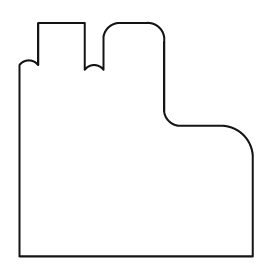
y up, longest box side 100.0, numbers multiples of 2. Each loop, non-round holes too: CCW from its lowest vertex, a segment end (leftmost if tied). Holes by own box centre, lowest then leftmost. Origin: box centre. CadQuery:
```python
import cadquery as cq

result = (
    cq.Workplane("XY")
    .moveTo(-50.0, -50.0)
    .lineTo(50.0, -50.0)
    .lineTo(50.0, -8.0)
    .threePointArc((46.0, 2.0), (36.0, 6.0))
    .lineTo(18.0, 6.0)
    .threePointArc((14.0, 8.0), (12.0, 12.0))
    .lineTo(12.0, 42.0)
    .threePointArc((10.0, 48.0), (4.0, 50.0))
    .lineTo(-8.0, 50.0)
    .threePointArc((-12.0, 48.0), (-14.0, 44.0))
    .lineTo(-14.0, 30.0)
    .threePointArc((-18.0, 32.0), (-22.0, 30.0))
    .lineTo(-22.0, 50.0)
    .lineTo(-42.0, 50.0)
    .lineTo(-42.0, 32.0)
    .threePointArc((-46.0, 34.0), (-50.0, 32.0))
    .close()
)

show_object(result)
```